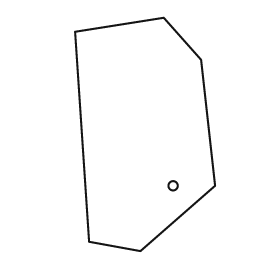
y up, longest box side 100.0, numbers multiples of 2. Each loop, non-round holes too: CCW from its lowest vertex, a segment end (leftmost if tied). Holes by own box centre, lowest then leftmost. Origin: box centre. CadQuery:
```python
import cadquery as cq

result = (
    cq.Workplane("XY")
    .moveTo(-2.0, -50.0)
    .lineTo(30.0, -22.0)
    .lineTo(24.0, 32.0)
    .lineTo(8.0, 50.0)
    .lineTo(-30.0, 44.0)
    .lineTo(-24.0, -46.0)
    .close()
    .moveTo(12.0, -22.0)
    .circle(2.0)
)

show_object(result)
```